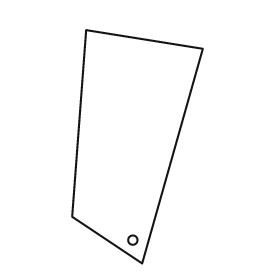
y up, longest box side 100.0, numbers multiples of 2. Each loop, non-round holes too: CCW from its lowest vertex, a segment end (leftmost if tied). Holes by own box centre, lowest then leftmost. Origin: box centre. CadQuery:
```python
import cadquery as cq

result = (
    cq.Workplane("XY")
    .moveTo(2.0, -50.0)
    .lineTo(28.0, 42.0)
    .lineTo(-22.0, 50.0)
    .lineTo(-28.0, -30.0)
    .close()
    .moveTo(-2.0, -40.0)
    .circle(2.0)
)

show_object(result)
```